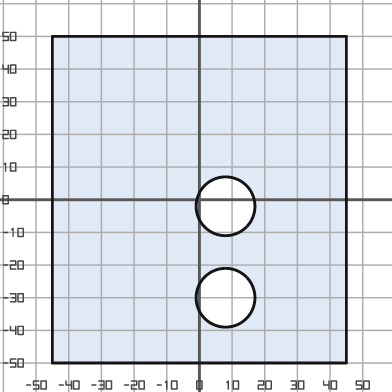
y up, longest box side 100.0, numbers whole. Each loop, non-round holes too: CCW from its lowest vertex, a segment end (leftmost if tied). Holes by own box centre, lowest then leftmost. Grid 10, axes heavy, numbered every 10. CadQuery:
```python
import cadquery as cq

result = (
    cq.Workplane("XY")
    .moveTo(-45.0, -50.0)
    .lineTo(45.0, -50.0)
    .lineTo(45.0, 50.0)
    .lineTo(-45.0, 50.0)
    .close()
    .moveTo(8.0, -30.0)
    .circle(9.0)
    .moveTo(8.0, -2.0)
    .circle(9.0)
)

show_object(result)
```